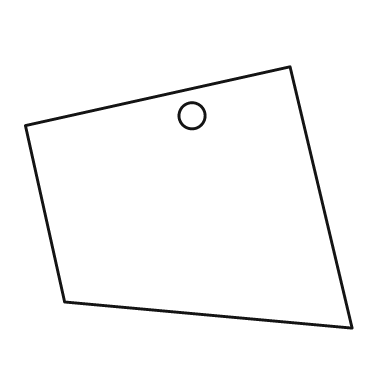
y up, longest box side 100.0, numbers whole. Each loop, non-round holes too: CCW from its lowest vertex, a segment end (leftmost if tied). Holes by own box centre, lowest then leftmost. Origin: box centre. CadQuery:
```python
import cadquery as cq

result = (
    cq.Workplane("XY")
    .moveTo(50.0, -40.0)
    .lineTo(31.0, 40.0)
    .lineTo(-50.0, 22.0)
    .lineTo(-38.0, -32.0)
    .close()
    .moveTo(1.0, 25.0)
    .circle(4.0)
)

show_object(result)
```